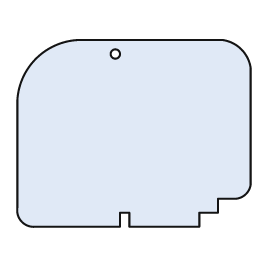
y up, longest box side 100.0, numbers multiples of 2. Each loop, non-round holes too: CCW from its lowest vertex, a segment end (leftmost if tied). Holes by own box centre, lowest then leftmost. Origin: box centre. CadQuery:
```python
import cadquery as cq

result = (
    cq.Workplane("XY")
    .moveTo(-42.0, -40.0)
    .lineTo(-6.0, -40.0)
    .lineTo(-6.0, -34.0)
    .lineTo(-2.0, -34.0)
    .lineTo(-2.0, -40.0)
    .lineTo(28.0, -40.0)
    .lineTo(28.0, -34.0)
    .lineTo(36.0, -34.0)
    .lineTo(36.0, -28.0)
    .lineTo(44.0, -28.0)
    .threePointArc((48.0, -26.0), (50.0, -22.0))
    .lineTo(50.0, 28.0)
    .threePointArc((46.0, 36.0), (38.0, 40.0))
    .lineTo(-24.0, 40.0)
    .threePointArc((-42.0, 32.0), (-50.0, 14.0))
    .lineTo(-50.0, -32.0)
    .threePointArc((-48.0, -38.0), (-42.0, -40.0))
    .close()
    .moveTo(-8.0, 34.0)
    .circle(2.0)
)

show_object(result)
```